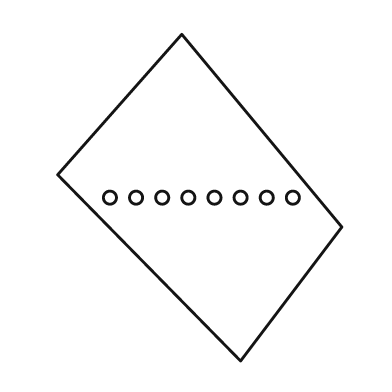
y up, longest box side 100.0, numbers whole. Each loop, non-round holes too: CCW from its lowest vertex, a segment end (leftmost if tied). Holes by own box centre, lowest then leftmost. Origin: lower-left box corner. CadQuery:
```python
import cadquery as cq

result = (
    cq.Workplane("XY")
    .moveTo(56.0, 0.0)
    .lineTo(87.0, 41.0)
    .lineTo(38.0, 100.0)
    .lineTo(0.0, 57.0)
    .close()
    .moveTo(16.0, 50.0)
    .circle(2.0)
    .moveTo(24.0, 50.0)
    .circle(2.0)
    .moveTo(32.0, 50.0)
    .circle(2.0)
    .moveTo(40.0, 50.0)
    .circle(2.0)
    .moveTo(48.0, 50.0)
    .circle(2.0)
    .moveTo(56.0, 50.0)
    .circle(2.0)
    .moveTo(64.0, 50.0)
    .circle(2.0)
    .moveTo(72.0, 50.0)
    .circle(2.0)
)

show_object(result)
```